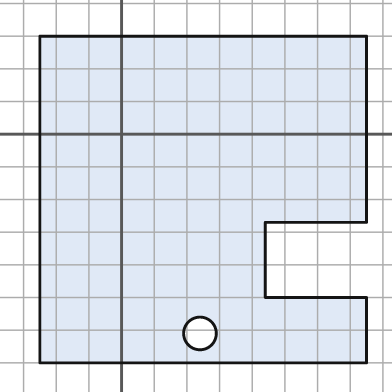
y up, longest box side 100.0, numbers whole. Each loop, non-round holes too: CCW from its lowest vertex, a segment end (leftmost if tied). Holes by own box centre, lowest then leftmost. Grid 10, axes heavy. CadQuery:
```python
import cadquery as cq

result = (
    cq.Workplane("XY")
    .moveTo(-25.0, -70.0)
    .lineTo(75.0, -70.0)
    .lineTo(75.0, -50.0)
    .lineTo(44.0, -50.0)
    .lineTo(44.0, -27.0)
    .lineTo(75.0, -27.0)
    .lineTo(75.0, 30.0)
    .lineTo(-25.0, 30.0)
    .close()
    .moveTo(24.0, -61.0)
    .circle(5.0)
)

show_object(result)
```